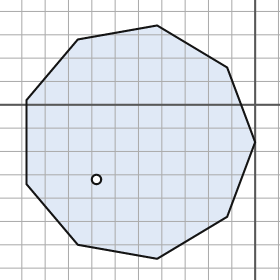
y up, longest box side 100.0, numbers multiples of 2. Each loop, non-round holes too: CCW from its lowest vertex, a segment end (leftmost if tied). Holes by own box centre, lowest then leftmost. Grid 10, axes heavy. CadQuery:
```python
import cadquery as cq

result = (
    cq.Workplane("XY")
    .moveTo(-42.0, -66.0)
    .lineTo(-12.0, -48.0)
    .lineTo(0.0, -16.0)
    .lineTo(-12.0, 16.0)
    .lineTo(-42.0, 34.0)
    .lineTo(-76.0, 28.0)
    .lineTo(-98.0, 2.0)
    .lineTo(-98.0, -34.0)
    .lineTo(-76.0, -60.0)
    .close()
    .moveTo(-68.0, -32.0)
    .circle(2.0)
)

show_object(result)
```